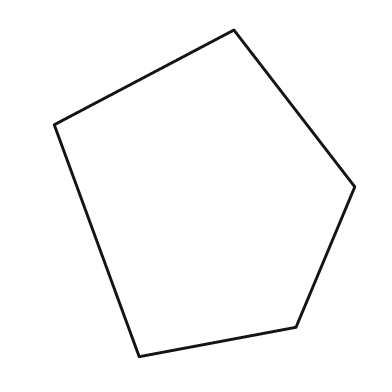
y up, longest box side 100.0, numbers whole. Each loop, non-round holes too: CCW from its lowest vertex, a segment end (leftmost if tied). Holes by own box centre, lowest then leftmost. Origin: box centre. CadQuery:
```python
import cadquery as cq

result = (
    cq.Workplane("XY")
    .moveTo(-20.0, -50.0)
    .lineTo(28.0, -41.0)
    .lineTo(46.0, 2.0)
    .lineTo(9.0, 50.0)
    .lineTo(-46.0, 21.0)
    .close()
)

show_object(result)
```